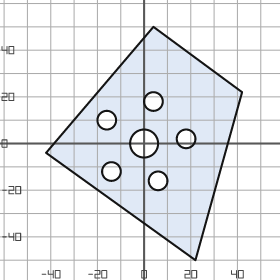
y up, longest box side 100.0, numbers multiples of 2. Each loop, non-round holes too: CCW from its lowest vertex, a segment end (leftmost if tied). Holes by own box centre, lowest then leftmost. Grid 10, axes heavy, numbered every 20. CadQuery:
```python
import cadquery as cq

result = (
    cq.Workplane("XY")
    .moveTo(22.0, -50.0)
    .lineTo(42.0, 22.0)
    .lineTo(4.0, 50.0)
    .lineTo(-42.0, -4.0)
    .close()
    .moveTo(6.0, -16.0)
    .circle(4.0)
    .moveTo(-14.0, -12.0)
    .circle(4.0)
    .moveTo(0.0, 0.0)
    .circle(6.0)
    .moveTo(18.0, 2.0)
    .circle(4.0)
    .moveTo(-16.0, 10.0)
    .circle(4.0)
    .moveTo(4.0, 18.0)
    .circle(4.0)
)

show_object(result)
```